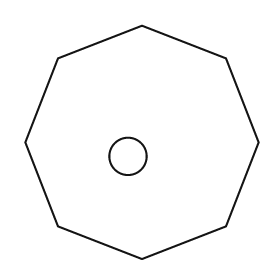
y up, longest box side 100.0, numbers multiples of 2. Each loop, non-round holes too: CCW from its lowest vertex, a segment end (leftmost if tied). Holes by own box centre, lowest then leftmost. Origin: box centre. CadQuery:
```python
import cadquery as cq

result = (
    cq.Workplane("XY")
    .moveTo(0.0, -50.0)
    .lineTo(36.0, -36.0)
    .lineTo(50.0, 0.0)
    .lineTo(36.0, 36.0)
    .lineTo(0.0, 50.0)
    .lineTo(-36.0, 36.0)
    .lineTo(-50.0, 0.0)
    .lineTo(-36.0, -36.0)
    .close()
    .moveTo(-6.0, -6.0)
    .circle(8.0)
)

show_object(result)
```